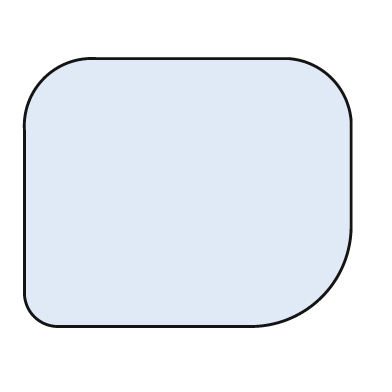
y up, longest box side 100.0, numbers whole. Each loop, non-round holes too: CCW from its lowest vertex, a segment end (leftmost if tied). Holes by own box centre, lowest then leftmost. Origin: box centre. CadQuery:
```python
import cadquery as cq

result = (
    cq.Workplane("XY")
    .moveTo(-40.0, -41.0)
    .lineTo(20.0, -41.0)
    .threePointArc((41.0, -32.0), (50.0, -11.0))
    .lineTo(50.0, 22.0)
    .threePointArc((44.0, 35.0), (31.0, 41.0))
    .lineTo(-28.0, 41.0)
    .threePointArc((-44.0, 35.0), (-50.0, 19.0))
    .lineTo(-50.0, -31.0)
    .threePointArc((-47.0, -38.0), (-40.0, -41.0))
    .close()
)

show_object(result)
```